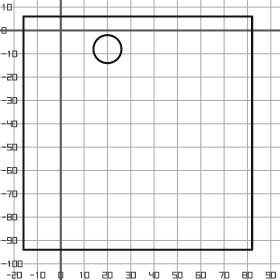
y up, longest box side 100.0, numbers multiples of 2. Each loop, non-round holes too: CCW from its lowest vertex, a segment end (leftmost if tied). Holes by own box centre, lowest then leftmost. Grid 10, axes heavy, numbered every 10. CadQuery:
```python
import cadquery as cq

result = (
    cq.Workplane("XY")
    .moveTo(-16.0, -94.0)
    .lineTo(82.0, -94.0)
    .lineTo(82.0, 6.0)
    .lineTo(-16.0, 6.0)
    .close()
    .moveTo(20.0, -8.0)
    .circle(6.0)
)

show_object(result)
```